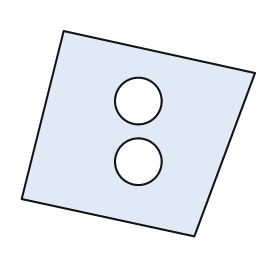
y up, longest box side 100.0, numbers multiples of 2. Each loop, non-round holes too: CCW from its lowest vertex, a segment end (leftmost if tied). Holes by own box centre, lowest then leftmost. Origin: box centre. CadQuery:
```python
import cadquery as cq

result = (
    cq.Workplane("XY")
    .moveTo(24.0, -44.0)
    .lineTo(50.0, 26.0)
    .lineTo(-32.0, 44.0)
    .lineTo(-50.0, -28.0)
    .close()
    .moveTo(0.0, -12.0)
    .circle(10.0)
    .moveTo(0.0, 14.0)
    .circle(10.0)
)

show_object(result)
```